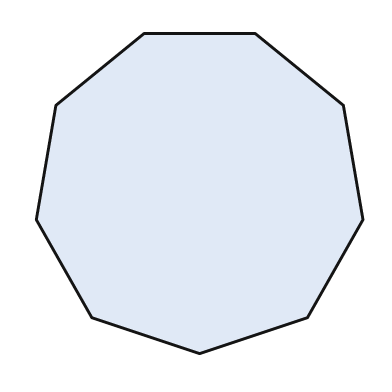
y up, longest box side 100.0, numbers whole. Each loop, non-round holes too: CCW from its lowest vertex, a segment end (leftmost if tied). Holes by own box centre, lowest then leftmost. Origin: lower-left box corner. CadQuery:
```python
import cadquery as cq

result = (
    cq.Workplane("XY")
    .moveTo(50.0, 0.0)
    .lineTo(83.0, 11.0)
    .lineTo(100.0, 41.0)
    .lineTo(94.0, 76.0)
    .lineTo(67.0, 98.0)
    .lineTo(33.0, 98.0)
    .lineTo(6.0, 76.0)
    .lineTo(0.0, 41.0)
    .lineTo(17.0, 11.0)
    .close()
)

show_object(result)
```